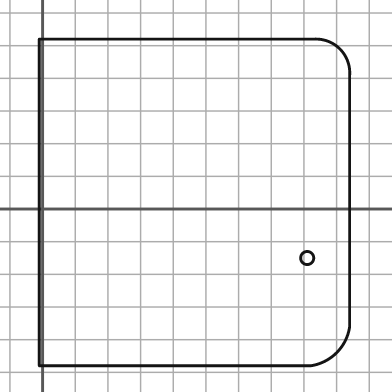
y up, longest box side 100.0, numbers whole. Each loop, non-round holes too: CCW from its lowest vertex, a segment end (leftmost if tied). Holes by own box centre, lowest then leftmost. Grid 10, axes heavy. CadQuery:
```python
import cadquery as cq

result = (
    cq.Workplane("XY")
    .moveTo(-1.0, -48.0)
    .lineTo(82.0, -48.0)
    .threePointArc((90.0, -44.0), (94.0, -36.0))
    .lineTo(94.0, 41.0)
    .threePointArc((91.0, 49.0), (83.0, 52.0))
    .lineTo(-1.0, 52.0)
    .close()
    .moveTo(81.0, -15.0)
    .circle(2.0)
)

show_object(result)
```